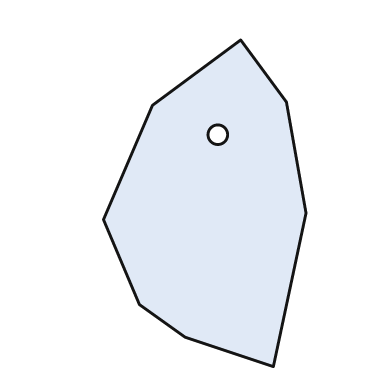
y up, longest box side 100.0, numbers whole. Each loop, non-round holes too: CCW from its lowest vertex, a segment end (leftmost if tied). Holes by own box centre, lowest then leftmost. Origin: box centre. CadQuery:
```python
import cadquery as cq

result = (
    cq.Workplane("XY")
    .moveTo(21.0, -50.0)
    .lineTo(31.0, -3.0)
    .lineTo(25.0, 31.0)
    .lineTo(11.0, 50.0)
    .lineTo(-16.0, 30.0)
    .lineTo(-31.0, -5.0)
    .lineTo(-20.0, -31.0)
    .lineTo(-6.0, -41.0)
    .close()
    .moveTo(4.0, 21.0)
    .circle(3.0)
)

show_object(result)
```